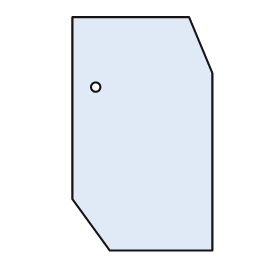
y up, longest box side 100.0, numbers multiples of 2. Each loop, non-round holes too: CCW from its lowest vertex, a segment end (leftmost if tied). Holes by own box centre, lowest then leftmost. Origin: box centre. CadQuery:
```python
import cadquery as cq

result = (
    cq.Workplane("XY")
    .moveTo(-14.0, -50.0)
    .lineTo(30.0, -50.0)
    .lineTo(30.0, 26.0)
    .lineTo(20.0, 50.0)
    .lineTo(-30.0, 50.0)
    .lineTo(-30.0, -28.0)
    .close()
    .moveTo(-20.0, 20.0)
    .circle(2.0)
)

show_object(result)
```